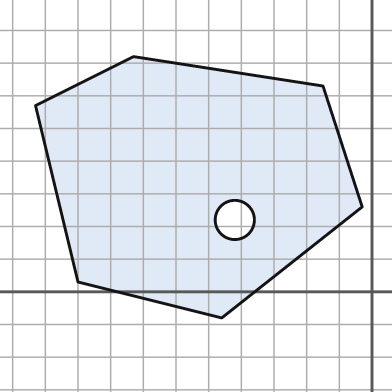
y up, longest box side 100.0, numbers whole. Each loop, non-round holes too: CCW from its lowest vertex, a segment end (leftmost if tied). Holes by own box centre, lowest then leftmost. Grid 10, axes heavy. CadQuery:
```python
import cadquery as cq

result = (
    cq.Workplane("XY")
    .moveTo(-46.0, -8.0)
    .lineTo(-3.0, 26.0)
    .lineTo(-15.0, 63.0)
    .lineTo(-73.0, 72.0)
    .lineTo(-103.0, 57.0)
    .lineTo(-90.0, 3.0)
    .close()
    .moveTo(-42.0, 22.0)
    .circle(6.0)
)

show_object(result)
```